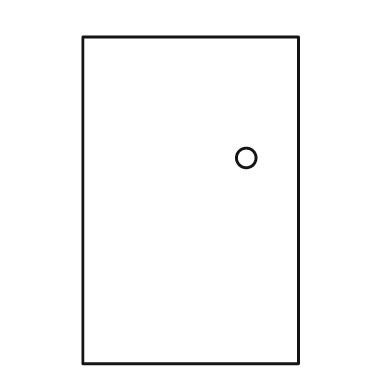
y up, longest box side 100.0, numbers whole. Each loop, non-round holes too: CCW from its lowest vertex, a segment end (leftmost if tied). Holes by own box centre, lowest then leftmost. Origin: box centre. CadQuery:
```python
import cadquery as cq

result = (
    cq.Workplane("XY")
    .moveTo(-33.0, -50.0)
    .lineTo(33.0, -50.0)
    .lineTo(33.0, 50.0)
    .lineTo(-33.0, 50.0)
    .close()
    .moveTo(17.0, 13.0)
    .circle(3.0)
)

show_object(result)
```